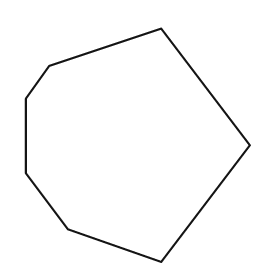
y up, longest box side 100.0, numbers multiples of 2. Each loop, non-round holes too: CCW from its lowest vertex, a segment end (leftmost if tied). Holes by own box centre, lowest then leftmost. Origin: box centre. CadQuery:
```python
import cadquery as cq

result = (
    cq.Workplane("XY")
    .moveTo(10.0, -50.0)
    .lineTo(48.0, 0.0)
    .lineTo(10.0, 50.0)
    .lineTo(-38.0, 34.0)
    .lineTo(-48.0, 20.0)
    .lineTo(-48.0, -12.0)
    .lineTo(-30.0, -36.0)
    .close()
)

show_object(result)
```